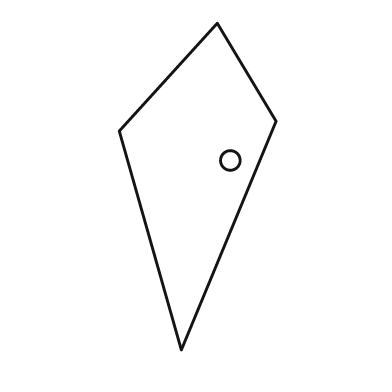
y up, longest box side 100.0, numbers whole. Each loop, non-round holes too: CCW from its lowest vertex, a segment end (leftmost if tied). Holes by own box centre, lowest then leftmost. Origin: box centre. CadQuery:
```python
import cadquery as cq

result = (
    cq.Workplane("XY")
    .moveTo(-5.0, -50.0)
    .lineTo(24.0, 20.0)
    .lineTo(6.0, 50.0)
    .lineTo(-24.0, 17.0)
    .close()
    .moveTo(10.0, 8.0)
    .circle(3.0)
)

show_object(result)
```